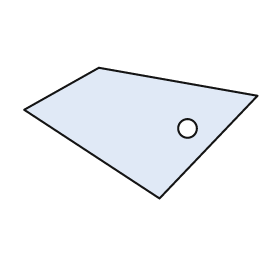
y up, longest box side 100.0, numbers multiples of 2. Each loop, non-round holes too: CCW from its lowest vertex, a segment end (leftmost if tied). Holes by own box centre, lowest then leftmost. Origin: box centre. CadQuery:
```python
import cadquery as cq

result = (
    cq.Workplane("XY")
    .moveTo(8.0, -28.0)
    .lineTo(50.0, 16.0)
    .lineTo(-18.0, 28.0)
    .lineTo(-50.0, 10.0)
    .close()
    .moveTo(20.0, 2.0)
    .circle(4.0)
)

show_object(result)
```